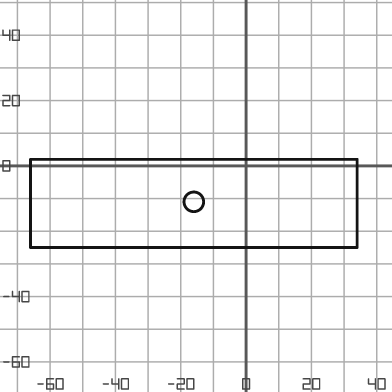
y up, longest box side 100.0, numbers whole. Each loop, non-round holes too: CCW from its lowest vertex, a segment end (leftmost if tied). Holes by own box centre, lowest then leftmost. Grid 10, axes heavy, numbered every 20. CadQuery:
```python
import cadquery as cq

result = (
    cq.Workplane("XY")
    .moveTo(-66.0, -25.0)
    .lineTo(34.0, -25.0)
    .lineTo(34.0, 2.0)
    .lineTo(-66.0, 2.0)
    .close()
    .moveTo(-16.0, -11.0)
    .circle(3.0)
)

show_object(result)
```